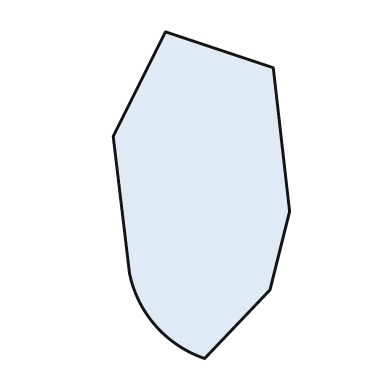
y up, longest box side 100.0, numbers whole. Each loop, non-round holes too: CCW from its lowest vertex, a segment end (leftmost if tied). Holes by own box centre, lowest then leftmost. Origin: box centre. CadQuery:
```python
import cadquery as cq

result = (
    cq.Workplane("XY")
    .moveTo(1.0, -50.0)
    .lineTo(21.0, -29.0)
    .lineTo(27.0, -5.0)
    .lineTo(22.0, 39.0)
    .lineTo(-11.0, 50.0)
    .lineTo(-27.0, 18.0)
    .lineTo(-22.0, -24.0)
    .threePointArc((-14.0, -40.0), (1.0, -50.0))
    .close()
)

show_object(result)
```